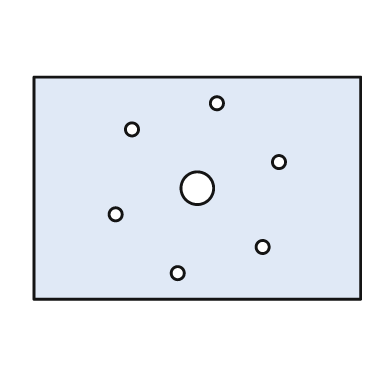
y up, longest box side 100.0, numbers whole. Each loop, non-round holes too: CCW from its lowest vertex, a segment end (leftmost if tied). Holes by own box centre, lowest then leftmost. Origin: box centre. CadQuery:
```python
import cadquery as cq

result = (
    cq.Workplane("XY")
    .moveTo(-50.0, -34.0)
    .lineTo(50.0, -34.0)
    .lineTo(50.0, 34.0)
    .lineTo(-50.0, 34.0)
    .close()
    .moveTo(-6.0, -26.0)
    .circle(2.0)
    .moveTo(20.0, -18.0)
    .circle(2.0)
    .moveTo(-25.0, -8.0)
    .circle(2.0)
    .moveTo(0.0, 0.0)
    .circle(5.0)
    .moveTo(25.0, 8.0)
    .circle(2.0)
    .moveTo(-20.0, 18.0)
    .circle(2.0)
    .moveTo(6.0, 26.0)
    .circle(2.0)
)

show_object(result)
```